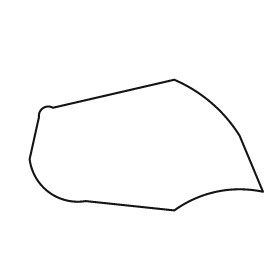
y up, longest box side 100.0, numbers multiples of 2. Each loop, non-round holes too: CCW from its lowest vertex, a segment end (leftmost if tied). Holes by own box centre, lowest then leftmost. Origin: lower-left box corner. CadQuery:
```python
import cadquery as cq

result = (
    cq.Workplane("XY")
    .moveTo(62.0, 0.0)
    .threePointArc((80.0, 8.0), (100.0, 8.0))
    .lineTo(90.0, 32.0)
    .threePointArc((78.0, 46.0), (62.0, 56.0))
    .lineTo(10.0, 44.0)
    .threePointArc((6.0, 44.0), (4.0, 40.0))
    .lineTo(0.0, 22.0)
    .threePointArc((8.0, 8.0), (24.0, 4.0))
    .close()
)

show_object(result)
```